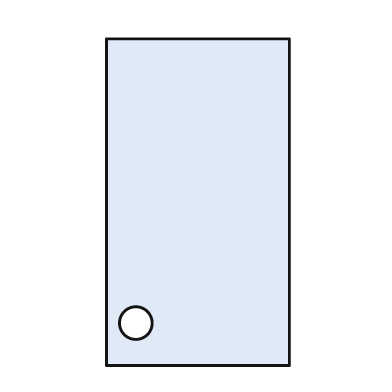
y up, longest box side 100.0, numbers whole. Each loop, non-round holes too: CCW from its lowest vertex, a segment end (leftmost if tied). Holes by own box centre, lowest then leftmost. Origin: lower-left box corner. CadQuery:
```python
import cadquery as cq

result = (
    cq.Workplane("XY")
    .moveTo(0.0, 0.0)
    .lineTo(56.0, 0.0)
    .lineTo(56.0, 100.0)
    .lineTo(0.0, 100.0)
    .close()
    .moveTo(9.0, 13.0)
    .circle(5.0)
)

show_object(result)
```